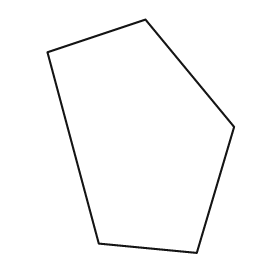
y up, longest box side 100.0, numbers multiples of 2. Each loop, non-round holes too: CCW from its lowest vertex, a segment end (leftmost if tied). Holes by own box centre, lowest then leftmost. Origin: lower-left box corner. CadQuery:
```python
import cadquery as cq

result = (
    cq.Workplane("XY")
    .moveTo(64.0, 0.0)
    .lineTo(80.0, 54.0)
    .lineTo(42.0, 100.0)
    .lineTo(0.0, 86.0)
    .lineTo(22.0, 4.0)
    .close()
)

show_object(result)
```